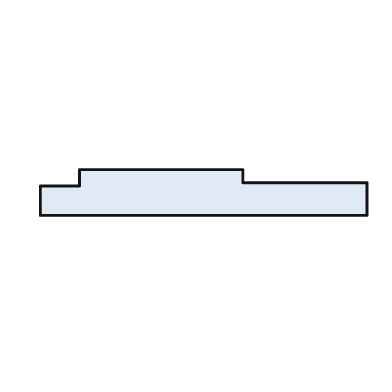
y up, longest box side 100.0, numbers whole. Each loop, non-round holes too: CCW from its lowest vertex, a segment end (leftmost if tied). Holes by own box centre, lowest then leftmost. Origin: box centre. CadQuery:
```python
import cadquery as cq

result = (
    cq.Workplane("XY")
    .moveTo(-50.0, -7.0)
    .lineTo(50.0, -7.0)
    .lineTo(50.0, 3.0)
    .lineTo(12.0, 3.0)
    .lineTo(12.0, 7.0)
    .lineTo(-38.0, 7.0)
    .lineTo(-38.0, 2.0)
    .lineTo(-50.0, 2.0)
    .close()
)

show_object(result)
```